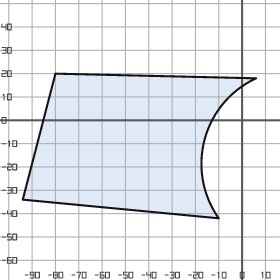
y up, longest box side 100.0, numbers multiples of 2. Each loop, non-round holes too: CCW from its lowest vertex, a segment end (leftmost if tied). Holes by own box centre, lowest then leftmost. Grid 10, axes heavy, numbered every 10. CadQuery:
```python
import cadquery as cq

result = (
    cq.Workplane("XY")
    .moveTo(-10.0, -42.0)
    .threePointArc((-16.0, -8.0), (6.0, 18.0))
    .lineTo(-80.0, 20.0)
    .lineTo(-94.0, -34.0)
    .close()
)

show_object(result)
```